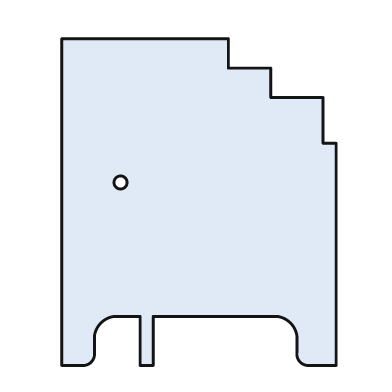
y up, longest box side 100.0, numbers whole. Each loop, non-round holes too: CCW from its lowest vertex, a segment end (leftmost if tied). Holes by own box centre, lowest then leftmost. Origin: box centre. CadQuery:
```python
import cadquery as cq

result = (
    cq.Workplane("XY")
    .moveTo(-42.0, -50.0)
    .lineTo(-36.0, -50.0)
    .threePointArc((-33.0, -49.0), (-32.0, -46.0))
    .lineTo(-32.0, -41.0)
    .threePointArc((-30.0, -37.0), (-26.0, -35.0))
    .lineTo(-18.0, -35.0)
    .lineTo(-18.0, -50.0)
    .lineTo(-14.0, -50.0)
    .lineTo(-14.0, -35.0)
    .lineTo(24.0, -35.0)
    .threePointArc((28.0, -37.0), (30.0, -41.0))
    .lineTo(30.0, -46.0)
    .threePointArc((31.0, -49.0), (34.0, -50.0))
    .lineTo(42.0, -50.0)
    .lineTo(42.0, 18.0)
    .lineTo(38.0, 18.0)
    .lineTo(38.0, 32.0)
    .lineTo(22.0, 32.0)
    .lineTo(22.0, 41.0)
    .lineTo(9.0, 41.0)
    .lineTo(9.0, 50.0)
    .lineTo(-42.0, 50.0)
    .close()
    .moveTo(-24.0, 6.0)
    .circle(2.0)
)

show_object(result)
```